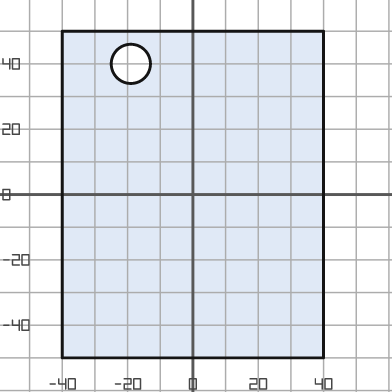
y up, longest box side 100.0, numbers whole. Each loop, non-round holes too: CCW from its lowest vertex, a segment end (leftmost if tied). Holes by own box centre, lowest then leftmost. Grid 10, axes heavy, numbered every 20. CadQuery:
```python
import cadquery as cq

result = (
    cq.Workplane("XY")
    .moveTo(-40.0, -50.0)
    .lineTo(40.0, -50.0)
    .lineTo(40.0, 50.0)
    .lineTo(-40.0, 50.0)
    .close()
    .moveTo(-19.0, 40.0)
    .circle(6.0)
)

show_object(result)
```